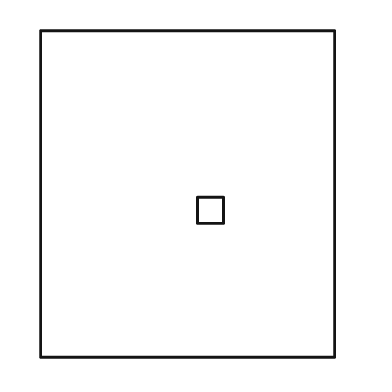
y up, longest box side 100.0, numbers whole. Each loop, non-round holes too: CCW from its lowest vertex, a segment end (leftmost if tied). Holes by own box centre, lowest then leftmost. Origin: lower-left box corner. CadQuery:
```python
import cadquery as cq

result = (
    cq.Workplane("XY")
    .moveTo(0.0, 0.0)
    .lineTo(90.0, 0.0)
    .lineTo(90.0, 100.0)
    .lineTo(0.0, 100.0)
    .close()
    .moveTo(48.0, 41.0)
    .lineTo(56.0, 41.0)
    .lineTo(56.0, 49.0)
    .lineTo(48.0, 49.0)
    .close()
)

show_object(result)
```